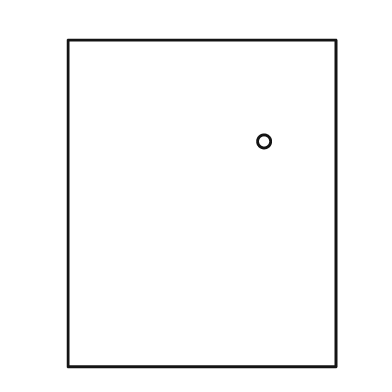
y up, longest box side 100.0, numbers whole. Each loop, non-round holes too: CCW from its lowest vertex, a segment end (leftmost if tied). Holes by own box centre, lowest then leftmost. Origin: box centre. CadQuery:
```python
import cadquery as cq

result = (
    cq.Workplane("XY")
    .moveTo(-41.0, -50.0)
    .lineTo(41.0, -50.0)
    .lineTo(41.0, 50.0)
    .lineTo(-41.0, 50.0)
    .close()
    .moveTo(19.0, 19.0)
    .circle(2.0)
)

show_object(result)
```